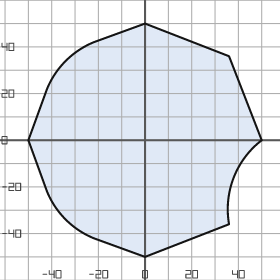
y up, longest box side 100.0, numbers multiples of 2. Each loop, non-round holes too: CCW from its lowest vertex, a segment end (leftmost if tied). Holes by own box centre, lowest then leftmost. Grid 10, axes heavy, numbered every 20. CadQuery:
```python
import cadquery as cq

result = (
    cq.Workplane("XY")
    .moveTo(0.0, -50.0)
    .lineTo(36.0, -36.0)
    .threePointArc((38.0, -16.0), (50.0, 0.0))
    .lineTo(36.0, 36.0)
    .lineTo(0.0, 50.0)
    .lineTo(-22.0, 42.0)
    .threePointArc((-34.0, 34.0), (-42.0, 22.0))
    .lineTo(-50.0, 0.0)
    .lineTo(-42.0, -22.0)
    .threePointArc((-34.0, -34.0), (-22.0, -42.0))
    .close()
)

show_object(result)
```